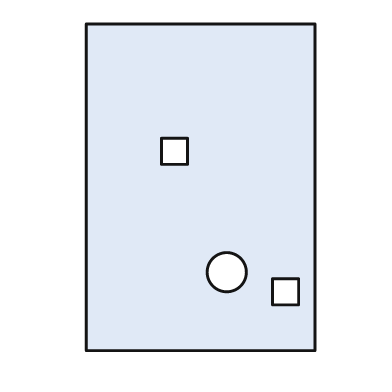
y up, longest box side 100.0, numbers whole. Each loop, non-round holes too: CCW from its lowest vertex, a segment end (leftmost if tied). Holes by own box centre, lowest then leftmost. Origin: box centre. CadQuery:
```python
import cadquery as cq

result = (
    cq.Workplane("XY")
    .moveTo(-35.0, -50.0)
    .lineTo(35.0, -50.0)
    .lineTo(35.0, 50.0)
    .lineTo(-35.0, 50.0)
    .close()
    .moveTo(22.0, -36.0)
    .lineTo(30.0, -36.0)
    .lineTo(30.0, -28.0)
    .lineTo(22.0, -28.0)
    .close()
    .moveTo(8.0, -26.0)
    .circle(6.0)
    .moveTo(-12.0, 7.0)
    .lineTo(-4.0, 7.0)
    .lineTo(-4.0, 15.0)
    .lineTo(-12.0, 15.0)
    .close()
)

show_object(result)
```